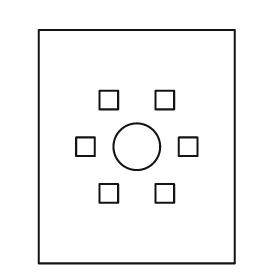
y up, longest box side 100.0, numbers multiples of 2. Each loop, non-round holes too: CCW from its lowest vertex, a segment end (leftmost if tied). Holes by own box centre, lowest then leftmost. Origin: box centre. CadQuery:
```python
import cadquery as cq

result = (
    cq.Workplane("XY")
    .moveTo(-42.0, -50.0)
    .lineTo(42.0, -50.0)
    .lineTo(42.0, 50.0)
    .lineTo(-42.0, 50.0)
    .close()
    .moveTo(-16.0, -24.0)
    .lineTo(-8.0, -24.0)
    .lineTo(-8.0, -16.0)
    .lineTo(-16.0, -16.0)
    .close()
    .moveTo(8.0, -24.0)
    .lineTo(16.0, -24.0)
    .lineTo(16.0, -16.0)
    .lineTo(8.0, -16.0)
    .close()
    .moveTo(-26.0, -4.0)
    .lineTo(-18.0, -4.0)
    .lineTo(-18.0, 4.0)
    .lineTo(-26.0, 4.0)
    .close()
    .moveTo(0.0, 0.0)
    .circle(10.0)
    .moveTo(18.0, -4.0)
    .lineTo(26.0, -4.0)
    .lineTo(26.0, 4.0)
    .lineTo(18.0, 4.0)
    .close()
    .moveTo(-16.0, 16.0)
    .lineTo(-8.0, 16.0)
    .lineTo(-8.0, 24.0)
    .lineTo(-16.0, 24.0)
    .close()
    .moveTo(8.0, 16.0)
    .lineTo(16.0, 16.0)
    .lineTo(16.0, 24.0)
    .lineTo(8.0, 24.0)
    .close()
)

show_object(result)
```